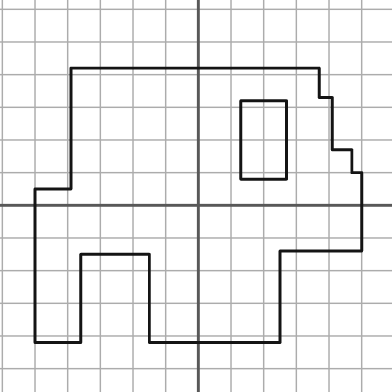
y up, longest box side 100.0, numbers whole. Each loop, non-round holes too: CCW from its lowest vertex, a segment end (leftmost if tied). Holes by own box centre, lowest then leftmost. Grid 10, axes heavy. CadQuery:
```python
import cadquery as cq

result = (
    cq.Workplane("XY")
    .moveTo(-50.0, -42.0)
    .lineTo(-36.0, -42.0)
    .lineTo(-36.0, -15.0)
    .lineTo(-15.0, -15.0)
    .lineTo(-15.0, -42.0)
    .lineTo(25.0, -42.0)
    .lineTo(25.0, -14.0)
    .lineTo(50.0, -14.0)
    .lineTo(50.0, 10.0)
    .lineTo(47.0, 10.0)
    .lineTo(47.0, 17.0)
    .lineTo(41.0, 17.0)
    .lineTo(41.0, 33.0)
    .lineTo(37.0, 33.0)
    .lineTo(37.0, 42.0)
    .lineTo(-39.0, 42.0)
    .lineTo(-39.0, 5.0)
    .lineTo(-50.0, 5.0)
    .close()
    .moveTo(13.0, 8.0)
    .lineTo(27.0, 8.0)
    .lineTo(27.0, 32.0)
    .lineTo(13.0, 32.0)
    .close()
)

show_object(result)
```